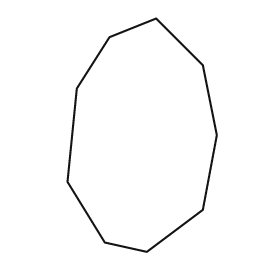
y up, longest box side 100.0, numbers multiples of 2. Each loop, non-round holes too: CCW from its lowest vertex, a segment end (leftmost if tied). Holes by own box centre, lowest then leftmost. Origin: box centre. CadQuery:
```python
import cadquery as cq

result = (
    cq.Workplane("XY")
    .moveTo(2.0, -50.0)
    .lineTo(26.0, -32.0)
    .lineTo(32.0, 0.0)
    .lineTo(26.0, 30.0)
    .lineTo(6.0, 50.0)
    .lineTo(-14.0, 42.0)
    .lineTo(-28.0, 20.0)
    .lineTo(-32.0, -20.0)
    .lineTo(-16.0, -46.0)
    .close()
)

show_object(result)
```